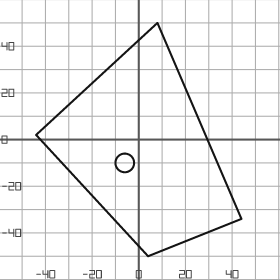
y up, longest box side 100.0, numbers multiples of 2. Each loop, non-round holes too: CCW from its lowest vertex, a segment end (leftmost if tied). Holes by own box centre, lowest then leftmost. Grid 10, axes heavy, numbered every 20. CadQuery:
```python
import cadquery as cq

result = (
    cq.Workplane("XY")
    .moveTo(4.0, -50.0)
    .lineTo(44.0, -34.0)
    .lineTo(8.0, 50.0)
    .lineTo(-44.0, 2.0)
    .close()
    .moveTo(-6.0, -10.0)
    .circle(4.0)
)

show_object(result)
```